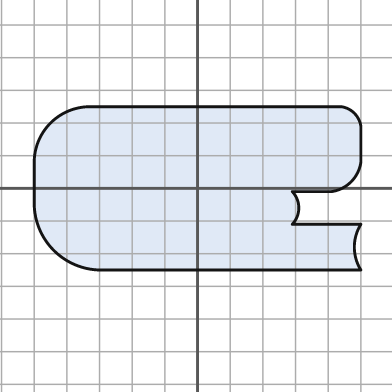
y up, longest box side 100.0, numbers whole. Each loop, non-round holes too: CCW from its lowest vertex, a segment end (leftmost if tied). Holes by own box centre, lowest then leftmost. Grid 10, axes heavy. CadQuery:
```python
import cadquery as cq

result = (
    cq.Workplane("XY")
    .moveTo(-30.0, -25.0)
    .lineTo(50.0, -25.0)
    .threePointArc((48.0, -18.0), (50.0, -11.0))
    .lineTo(29.0, -11.0)
    .threePointArc((31.0, -6.0), (29.0, -1.0))
    .lineTo(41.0, -1.0)
    .threePointArc((47.0, 2.0), (50.0, 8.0))
    .lineTo(50.0, 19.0)
    .threePointArc((48.0, 23.0), (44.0, 25.0))
    .lineTo(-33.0, 25.0)
    .threePointArc((-45.0, 20.0), (-50.0, 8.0))
    .lineTo(-50.0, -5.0)
    .threePointArc((-44.0, -19.0), (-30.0, -25.0))
    .close()
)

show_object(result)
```